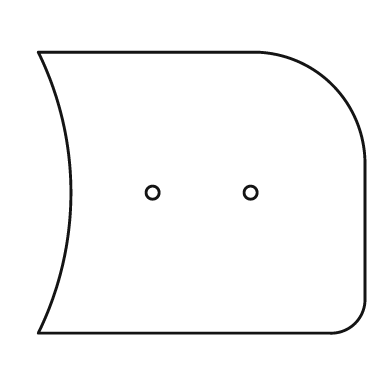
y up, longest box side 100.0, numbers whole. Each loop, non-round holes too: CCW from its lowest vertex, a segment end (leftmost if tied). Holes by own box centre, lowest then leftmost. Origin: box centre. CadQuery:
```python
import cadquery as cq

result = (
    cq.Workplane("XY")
    .moveTo(-50.0, -43.0)
    .lineTo(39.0, -43.0)
    .threePointArc((47.0, -40.0), (50.0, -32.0))
    .lineTo(50.0, 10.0)
    .threePointArc((40.0, 33.0), (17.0, 43.0))
    .lineTo(-50.0, 43.0)
    .threePointArc((-40.0, 0.0), (-50.0, -43.0))
    .close()
    .moveTo(-15.0, 0.0)
    .circle(2.0)
    .moveTo(15.0, 0.0)
    .circle(2.0)
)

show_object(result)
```